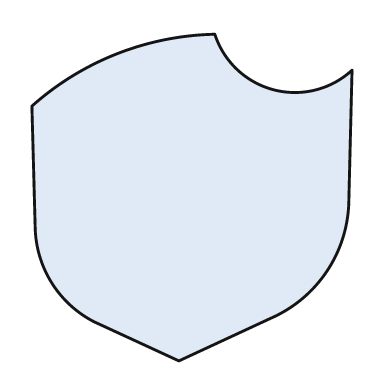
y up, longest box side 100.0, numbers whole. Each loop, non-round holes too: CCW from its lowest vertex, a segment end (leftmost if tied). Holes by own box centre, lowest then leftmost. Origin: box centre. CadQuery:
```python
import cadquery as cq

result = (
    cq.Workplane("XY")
    .moveTo(-4.0, -50.0)
    .lineTo(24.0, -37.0)
    .threePointArc((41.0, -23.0), (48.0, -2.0))
    .lineTo(49.0, 39.0)
    .threePointArc((25.0, 33.0), (7.0, 50.0))
    .threePointArc((-23.0, 44.0), (-49.0, 28.0))
    .lineTo(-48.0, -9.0)
    .threePointArc((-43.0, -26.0), (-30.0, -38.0))
    .close()
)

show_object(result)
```